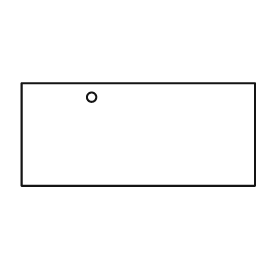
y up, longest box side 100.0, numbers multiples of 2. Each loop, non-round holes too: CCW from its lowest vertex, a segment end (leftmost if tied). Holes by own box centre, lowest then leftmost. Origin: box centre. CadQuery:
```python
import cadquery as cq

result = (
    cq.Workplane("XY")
    .moveTo(-50.0, -22.0)
    .lineTo(50.0, -22.0)
    .lineTo(50.0, 22.0)
    .lineTo(-50.0, 22.0)
    .close()
    .moveTo(-20.0, 16.0)
    .circle(2.0)
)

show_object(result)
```